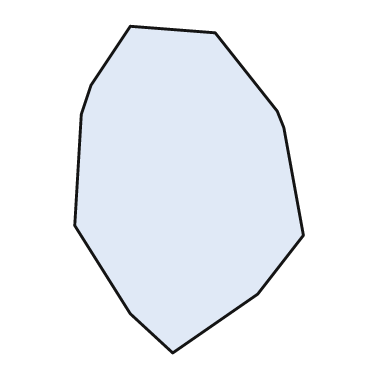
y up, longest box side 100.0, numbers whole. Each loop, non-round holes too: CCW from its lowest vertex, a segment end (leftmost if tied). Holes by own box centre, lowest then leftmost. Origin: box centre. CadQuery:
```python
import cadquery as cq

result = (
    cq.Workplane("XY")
    .moveTo(-5.0, -50.0)
    .lineTo(21.0, -32.0)
    .lineTo(35.0, -14.0)
    .lineTo(29.0, 19.0)
    .lineTo(27.0, 24.0)
    .lineTo(8.0, 48.0)
    .lineTo(-18.0, 50.0)
    .lineTo(-30.0, 32.0)
    .lineTo(-33.0, 23.0)
    .lineTo(-35.0, -11.0)
    .lineTo(-18.0, -38.0)
    .close()
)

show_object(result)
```